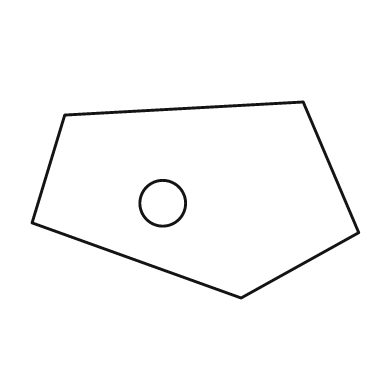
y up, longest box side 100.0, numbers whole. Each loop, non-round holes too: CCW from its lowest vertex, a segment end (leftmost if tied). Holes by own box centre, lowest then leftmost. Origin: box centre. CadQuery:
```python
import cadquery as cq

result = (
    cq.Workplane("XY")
    .moveTo(14.0, -30.0)
    .lineTo(50.0, -10.0)
    .lineTo(33.0, 30.0)
    .lineTo(-40.0, 26.0)
    .lineTo(-50.0, -7.0)
    .close()
    .moveTo(-10.0, -1.0)
    .circle(7.0)
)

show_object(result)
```